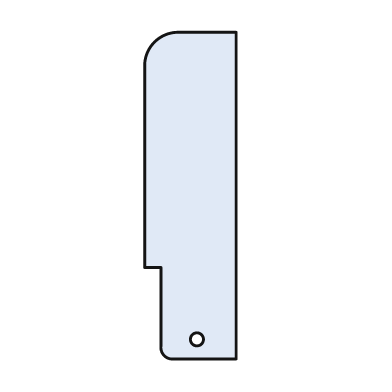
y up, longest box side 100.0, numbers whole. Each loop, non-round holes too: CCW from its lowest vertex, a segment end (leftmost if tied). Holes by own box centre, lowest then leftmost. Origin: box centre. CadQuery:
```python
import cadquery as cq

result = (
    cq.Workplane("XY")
    .moveTo(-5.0, -50.0)
    .lineTo(14.0, -50.0)
    .lineTo(14.0, 50.0)
    .lineTo(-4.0, 50.0)
    .threePointArc((-11.0, 47.0), (-14.0, 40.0))
    .lineTo(-14.0, -22.0)
    .lineTo(-9.0, -22.0)
    .lineTo(-9.0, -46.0)
    .threePointArc((-8.0, -49.0), (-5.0, -50.0))
    .close()
    .moveTo(2.0, -44.0)
    .circle(2.0)
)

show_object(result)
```